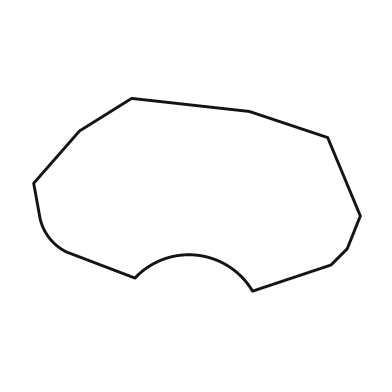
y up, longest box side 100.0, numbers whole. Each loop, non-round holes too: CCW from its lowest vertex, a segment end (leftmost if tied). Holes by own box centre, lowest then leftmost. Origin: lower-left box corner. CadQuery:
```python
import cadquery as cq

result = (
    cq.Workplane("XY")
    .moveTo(67.0, 0.0)
    .lineTo(91.0, 8.0)
    .lineTo(96.0, 13.0)
    .lineTo(100.0, 23.0)
    .lineTo(90.0, 47.0)
    .lineTo(66.0, 55.0)
    .lineTo(30.0, 59.0)
    .lineTo(14.0, 49.0)
    .lineTo(0.0, 33.0)
    .lineTo(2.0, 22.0)
    .threePointArc((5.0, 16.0), (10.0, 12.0))
    .lineTo(31.0, 4.0)
    .threePointArc((50.0, 11.0), (67.0, 0.0))
    .close()
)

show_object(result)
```